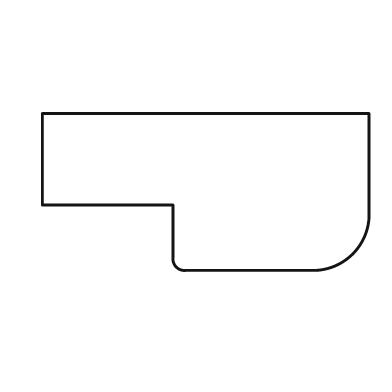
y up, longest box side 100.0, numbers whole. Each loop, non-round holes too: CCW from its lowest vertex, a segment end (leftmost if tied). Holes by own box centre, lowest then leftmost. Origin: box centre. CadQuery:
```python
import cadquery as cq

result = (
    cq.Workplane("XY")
    .moveTo(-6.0, -24.0)
    .lineTo(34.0, -24.0)
    .threePointArc((45.0, -19.0), (50.0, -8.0))
    .lineTo(50.0, 24.0)
    .lineTo(-50.0, 24.0)
    .lineTo(-50.0, -4.0)
    .lineTo(-10.0, -4.0)
    .lineTo(-10.0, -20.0)
    .threePointArc((-9.0, -23.0), (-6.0, -24.0))
    .close()
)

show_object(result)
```